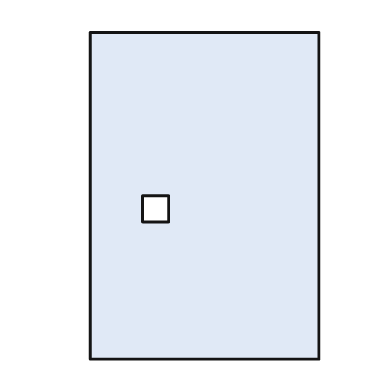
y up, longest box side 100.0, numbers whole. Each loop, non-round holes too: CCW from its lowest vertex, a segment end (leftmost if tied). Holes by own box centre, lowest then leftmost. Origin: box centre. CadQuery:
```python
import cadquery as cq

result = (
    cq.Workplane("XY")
    .moveTo(-35.0, -50.0)
    .lineTo(35.0, -50.0)
    .lineTo(35.0, 50.0)
    .lineTo(-35.0, 50.0)
    .close()
    .moveTo(-19.0, -8.0)
    .lineTo(-11.0, -8.0)
    .lineTo(-11.0, 0.0)
    .lineTo(-19.0, 0.0)
    .close()
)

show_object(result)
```